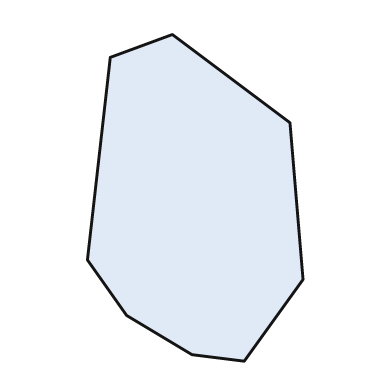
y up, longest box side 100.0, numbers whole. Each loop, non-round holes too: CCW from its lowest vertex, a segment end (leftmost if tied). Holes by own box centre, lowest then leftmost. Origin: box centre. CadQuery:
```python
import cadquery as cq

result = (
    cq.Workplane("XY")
    .moveTo(15.0, -50.0)
    .lineTo(33.0, -25.0)
    .lineTo(29.0, 23.0)
    .lineTo(-7.0, 50.0)
    .lineTo(-26.0, 43.0)
    .lineTo(-33.0, -19.0)
    .lineTo(-21.0, -36.0)
    .lineTo(-1.0, -48.0)
    .close()
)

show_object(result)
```